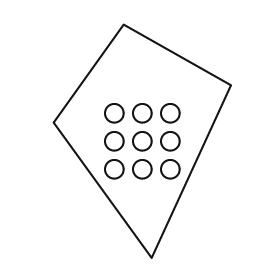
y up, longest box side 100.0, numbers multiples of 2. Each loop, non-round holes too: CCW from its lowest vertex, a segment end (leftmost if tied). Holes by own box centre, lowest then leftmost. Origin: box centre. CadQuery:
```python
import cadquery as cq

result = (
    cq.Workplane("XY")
    .moveTo(4.0, -50.0)
    .lineTo(38.0, 24.0)
    .lineTo(-8.0, 50.0)
    .lineTo(-38.0, 8.0)
    .close()
    .moveTo(-12.0, -12.0)
    .circle(4.0)
    .moveTo(0.0, -12.0)
    .circle(4.0)
    .moveTo(12.0, -12.0)
    .circle(4.0)
    .moveTo(-12.0, 0.0)
    .circle(4.0)
    .moveTo(0.0, 0.0)
    .circle(4.0)
    .moveTo(12.0, 0.0)
    .circle(4.0)
    .moveTo(-12.0, 12.0)
    .circle(4.0)
    .moveTo(0.0, 12.0)
    .circle(4.0)
    .moveTo(12.0, 12.0)
    .circle(4.0)
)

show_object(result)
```